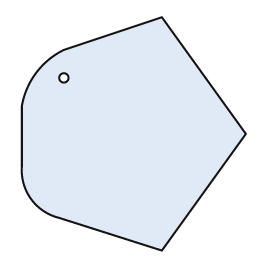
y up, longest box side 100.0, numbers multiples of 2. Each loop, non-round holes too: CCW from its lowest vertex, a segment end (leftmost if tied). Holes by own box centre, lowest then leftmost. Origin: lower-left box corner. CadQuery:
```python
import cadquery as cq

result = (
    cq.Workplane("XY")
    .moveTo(60.0, 0.0)
    .lineTo(96.0, 50.0)
    .lineTo(60.0, 100.0)
    .lineTo(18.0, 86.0)
    .threePointArc((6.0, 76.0), (0.0, 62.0))
    .lineTo(0.0, 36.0)
    .threePointArc((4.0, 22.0), (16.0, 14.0))
    .close()
    .moveTo(18.0, 74.0)
    .circle(2.0)
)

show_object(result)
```